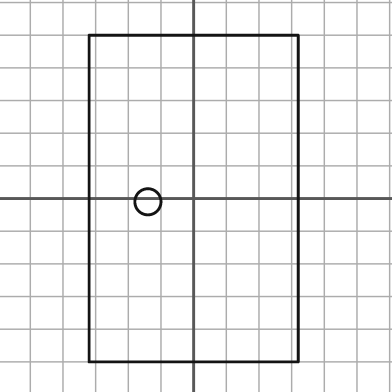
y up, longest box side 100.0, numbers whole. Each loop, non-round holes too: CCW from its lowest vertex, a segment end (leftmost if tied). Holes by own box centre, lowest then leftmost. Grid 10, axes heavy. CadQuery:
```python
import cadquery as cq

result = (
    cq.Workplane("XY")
    .moveTo(-32.0, -50.0)
    .lineTo(32.0, -50.0)
    .lineTo(32.0, 50.0)
    .lineTo(-32.0, 50.0)
    .close()
    .moveTo(-14.0, -1.0)
    .circle(4.0)
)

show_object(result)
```